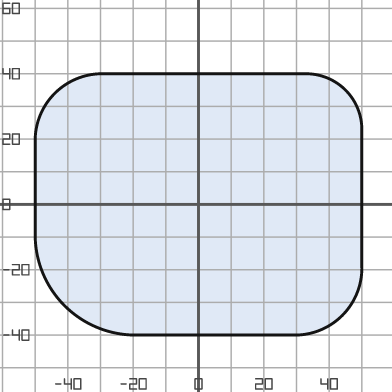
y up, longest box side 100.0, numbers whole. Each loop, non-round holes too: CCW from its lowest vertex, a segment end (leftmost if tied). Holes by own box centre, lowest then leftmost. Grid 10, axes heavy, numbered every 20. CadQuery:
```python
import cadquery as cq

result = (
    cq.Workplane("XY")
    .moveTo(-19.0, -40.0)
    .lineTo(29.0, -40.0)
    .threePointArc((44.0, -34.0), (50.0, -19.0))
    .lineTo(50.0, 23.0)
    .threePointArc((45.0, 35.0), (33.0, 40.0))
    .lineTo(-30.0, 40.0)
    .threePointArc((-44.0, 34.0), (-50.0, 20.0))
    .lineTo(-50.0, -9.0)
    .threePointArc((-41.0, -31.0), (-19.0, -40.0))
    .close()
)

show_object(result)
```